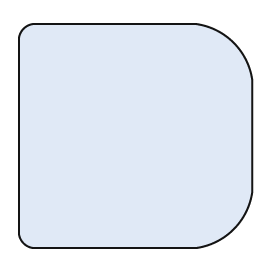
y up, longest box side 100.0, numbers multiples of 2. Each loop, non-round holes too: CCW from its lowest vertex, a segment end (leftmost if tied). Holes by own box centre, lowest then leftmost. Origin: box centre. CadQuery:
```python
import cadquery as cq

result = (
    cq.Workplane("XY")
    .moveTo(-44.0, -48.0)
    .lineTo(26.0, -48.0)
    .threePointArc((42.0, -40.0), (50.0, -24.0))
    .lineTo(50.0, 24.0)
    .threePointArc((42.0, 40.0), (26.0, 48.0))
    .lineTo(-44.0, 48.0)
    .threePointArc((-48.0, 46.0), (-50.0, 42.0))
    .lineTo(-50.0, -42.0)
    .threePointArc((-48.0, -46.0), (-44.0, -48.0))
    .close()
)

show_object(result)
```